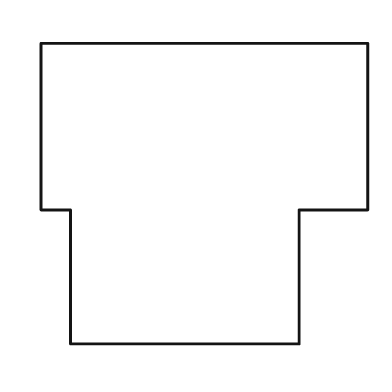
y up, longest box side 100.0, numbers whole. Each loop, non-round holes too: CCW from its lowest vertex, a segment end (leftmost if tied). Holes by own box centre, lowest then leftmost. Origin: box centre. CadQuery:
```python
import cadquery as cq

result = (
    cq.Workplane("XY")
    .moveTo(-41.0, -46.0)
    .lineTo(29.0, -46.0)
    .lineTo(29.0, -5.0)
    .lineTo(50.0, -5.0)
    .lineTo(50.0, 46.0)
    .lineTo(-50.0, 46.0)
    .lineTo(-50.0, -5.0)
    .lineTo(-41.0, -5.0)
    .close()
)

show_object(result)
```